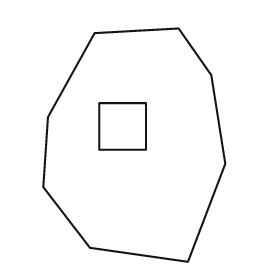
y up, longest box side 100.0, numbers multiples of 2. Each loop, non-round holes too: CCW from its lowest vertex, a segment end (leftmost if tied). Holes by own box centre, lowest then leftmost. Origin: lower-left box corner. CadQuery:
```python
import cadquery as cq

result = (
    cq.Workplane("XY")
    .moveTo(62.0, 0.0)
    .lineTo(78.0, 42.0)
    .lineTo(72.0, 80.0)
    .lineTo(58.0, 100.0)
    .lineTo(22.0, 98.0)
    .lineTo(2.0, 62.0)
    .lineTo(0.0, 32.0)
    .lineTo(20.0, 6.0)
    .close()
    .moveTo(24.0, 48.0)
    .lineTo(44.0, 48.0)
    .lineTo(44.0, 68.0)
    .lineTo(24.0, 68.0)
    .close()
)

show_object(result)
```